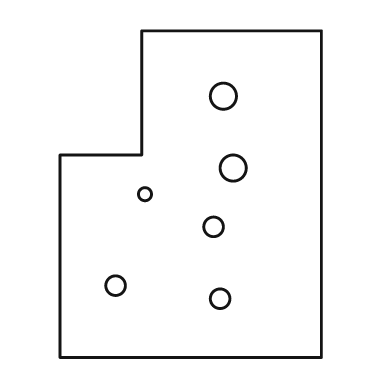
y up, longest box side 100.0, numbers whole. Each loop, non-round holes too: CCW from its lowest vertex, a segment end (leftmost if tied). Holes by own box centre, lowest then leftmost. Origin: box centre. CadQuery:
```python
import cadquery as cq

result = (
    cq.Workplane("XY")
    .moveTo(-40.0, -50.0)
    .lineTo(40.0, -50.0)
    .lineTo(40.0, 50.0)
    .lineTo(-15.0, 50.0)
    .lineTo(-15.0, 12.0)
    .lineTo(-40.0, 12.0)
    .close()
    .moveTo(9.0, -32.0)
    .circle(3.0)
    .moveTo(-23.0, -28.0)
    .circle(3.0)
    .moveTo(7.0, -10.0)
    .circle(3.0)
    .moveTo(-14.0, 0.0)
    .circle(2.0)
    .moveTo(13.0, 8.0)
    .circle(4.0)
    .moveTo(10.0, 30.0)
    .circle(4.0)
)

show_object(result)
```